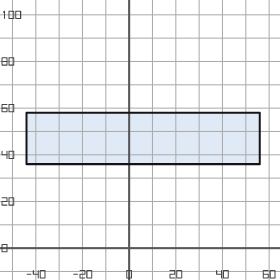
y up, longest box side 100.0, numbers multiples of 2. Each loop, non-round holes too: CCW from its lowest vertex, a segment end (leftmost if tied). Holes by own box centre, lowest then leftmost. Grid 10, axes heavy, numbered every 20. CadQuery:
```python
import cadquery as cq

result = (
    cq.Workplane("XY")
    .moveTo(-44.0, 36.0)
    .lineTo(56.0, 36.0)
    .lineTo(56.0, 58.0)
    .lineTo(-44.0, 58.0)
    .close()
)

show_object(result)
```